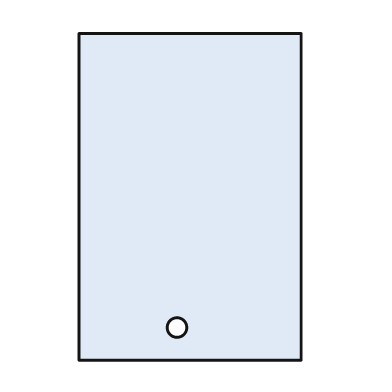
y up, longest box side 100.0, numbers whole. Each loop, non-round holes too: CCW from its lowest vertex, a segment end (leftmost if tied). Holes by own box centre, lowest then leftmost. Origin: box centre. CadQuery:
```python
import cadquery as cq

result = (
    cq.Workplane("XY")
    .moveTo(-34.0, -50.0)
    .lineTo(34.0, -50.0)
    .lineTo(34.0, 50.0)
    .lineTo(-34.0, 50.0)
    .close()
    .moveTo(-4.0, -40.0)
    .circle(3.0)
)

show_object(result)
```